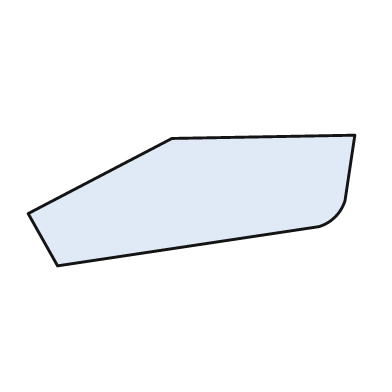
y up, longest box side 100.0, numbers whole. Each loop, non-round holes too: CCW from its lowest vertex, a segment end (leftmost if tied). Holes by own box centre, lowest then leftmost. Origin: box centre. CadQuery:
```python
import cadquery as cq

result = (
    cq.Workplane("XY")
    .moveTo(-41.0, -20.0)
    .lineTo(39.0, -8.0)
    .threePointArc((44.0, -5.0), (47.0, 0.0))
    .lineTo(50.0, 20.0)
    .lineTo(-6.0, 19.0)
    .lineTo(-50.0, -4.0)
    .close()
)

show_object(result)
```